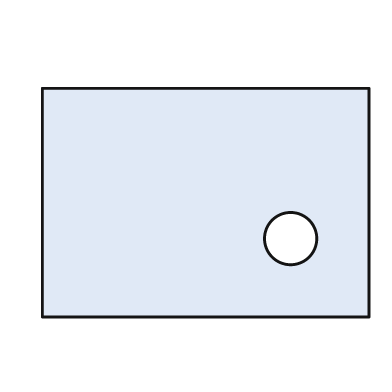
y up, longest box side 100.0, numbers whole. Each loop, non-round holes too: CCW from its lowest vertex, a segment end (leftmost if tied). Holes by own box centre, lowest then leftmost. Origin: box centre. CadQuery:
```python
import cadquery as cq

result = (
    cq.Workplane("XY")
    .moveTo(-50.0, -35.0)
    .lineTo(50.0, -35.0)
    .lineTo(50.0, 35.0)
    .lineTo(-50.0, 35.0)
    .close()
    .moveTo(26.0, -11.0)
    .circle(8.0)
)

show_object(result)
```